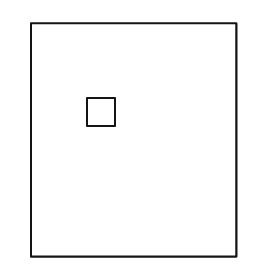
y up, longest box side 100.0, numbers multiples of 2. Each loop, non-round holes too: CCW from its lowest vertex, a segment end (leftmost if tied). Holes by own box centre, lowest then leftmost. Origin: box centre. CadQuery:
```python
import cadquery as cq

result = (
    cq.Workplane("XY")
    .moveTo(-44.0, -50.0)
    .lineTo(44.0, -50.0)
    .lineTo(44.0, 50.0)
    .lineTo(-44.0, 50.0)
    .close()
    .moveTo(-20.0, 6.0)
    .lineTo(-8.0, 6.0)
    .lineTo(-8.0, 18.0)
    .lineTo(-20.0, 18.0)
    .close()
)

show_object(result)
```